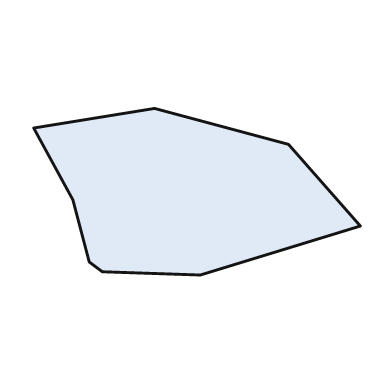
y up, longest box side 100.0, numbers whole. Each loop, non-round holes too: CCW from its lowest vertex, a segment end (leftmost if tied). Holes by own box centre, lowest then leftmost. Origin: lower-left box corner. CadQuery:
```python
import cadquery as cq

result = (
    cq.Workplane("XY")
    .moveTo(51.0, 0.0)
    .lineTo(100.0, 15.0)
    .lineTo(78.0, 40.0)
    .lineTo(37.0, 51.0)
    .lineTo(0.0, 45.0)
    .lineTo(12.0, 23.0)
    .lineTo(17.0, 4.0)
    .lineTo(21.0, 1.0)
    .close()
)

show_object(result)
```